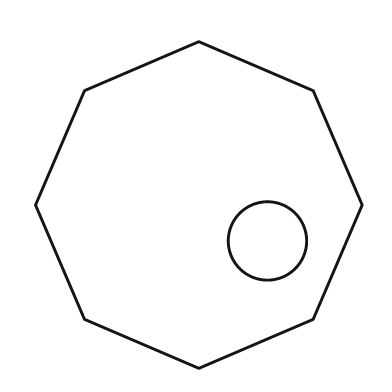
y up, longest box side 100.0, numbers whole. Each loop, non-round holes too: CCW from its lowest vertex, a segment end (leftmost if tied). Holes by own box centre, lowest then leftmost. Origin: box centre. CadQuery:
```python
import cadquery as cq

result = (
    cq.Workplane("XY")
    .moveTo(0.0, -50.0)
    .lineTo(35.0, -35.0)
    .lineTo(50.0, 0.0)
    .lineTo(35.0, 35.0)
    .lineTo(0.0, 50.0)
    .lineTo(-35.0, 35.0)
    .lineTo(-50.0, 0.0)
    .lineTo(-35.0, -35.0)
    .close()
    .moveTo(21.0, -11.0)
    .circle(12.0)
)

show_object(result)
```